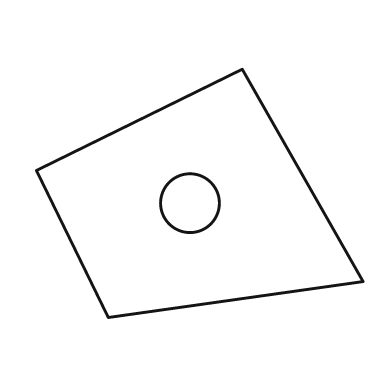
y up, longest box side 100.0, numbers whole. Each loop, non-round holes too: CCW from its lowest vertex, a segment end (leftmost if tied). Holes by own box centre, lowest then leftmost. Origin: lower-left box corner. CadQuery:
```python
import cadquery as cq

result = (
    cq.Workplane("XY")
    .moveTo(22.0, 0.0)
    .lineTo(100.0, 11.0)
    .lineTo(63.0, 76.0)
    .lineTo(0.0, 45.0)
    .close()
    .moveTo(47.0, 35.0)
    .circle(9.0)
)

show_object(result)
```